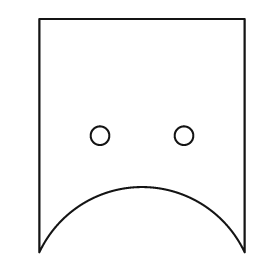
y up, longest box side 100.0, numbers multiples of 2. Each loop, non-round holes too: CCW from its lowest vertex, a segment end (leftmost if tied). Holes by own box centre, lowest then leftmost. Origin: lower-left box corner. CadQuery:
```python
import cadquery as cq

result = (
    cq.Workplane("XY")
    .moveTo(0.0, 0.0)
    .threePointArc((44.0, 28.0), (88.0, 0.0))
    .lineTo(88.0, 100.0)
    .lineTo(0.0, 100.0)
    .close()
    .moveTo(26.0, 50.0)
    .circle(4.0)
    .moveTo(62.0, 50.0)
    .circle(4.0)
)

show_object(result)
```